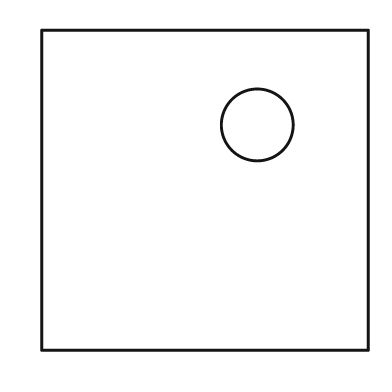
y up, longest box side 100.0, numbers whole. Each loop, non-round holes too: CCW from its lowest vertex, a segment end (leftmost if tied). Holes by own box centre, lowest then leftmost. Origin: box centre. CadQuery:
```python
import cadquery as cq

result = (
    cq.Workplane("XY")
    .moveTo(-50.0, -49.0)
    .lineTo(50.0, -49.0)
    .lineTo(50.0, 49.0)
    .lineTo(-50.0, 49.0)
    .close()
    .moveTo(16.0, 20.0)
    .circle(11.0)
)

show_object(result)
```